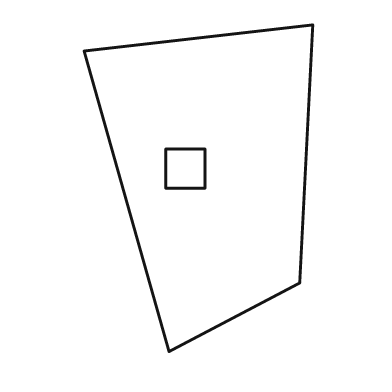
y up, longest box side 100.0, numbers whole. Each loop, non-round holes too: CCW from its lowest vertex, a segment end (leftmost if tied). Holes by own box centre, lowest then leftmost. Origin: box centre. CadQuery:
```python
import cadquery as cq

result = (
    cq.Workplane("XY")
    .moveTo(-9.0, -50.0)
    .lineTo(31.0, -29.0)
    .lineTo(35.0, 50.0)
    .lineTo(-35.0, 42.0)
    .close()
    .moveTo(-10.0, 0.0)
    .lineTo(2.0, 0.0)
    .lineTo(2.0, 12.0)
    .lineTo(-10.0, 12.0)
    .close()
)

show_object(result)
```